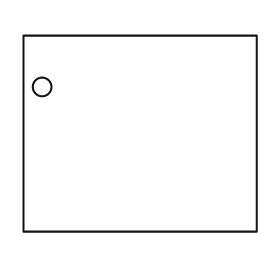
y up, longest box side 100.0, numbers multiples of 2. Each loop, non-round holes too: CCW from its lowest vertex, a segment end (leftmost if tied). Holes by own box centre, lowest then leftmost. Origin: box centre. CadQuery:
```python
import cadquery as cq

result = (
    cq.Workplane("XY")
    .moveTo(-50.0, -42.0)
    .lineTo(50.0, -42.0)
    .lineTo(50.0, 42.0)
    .lineTo(-50.0, 42.0)
    .close()
    .moveTo(-42.0, 20.0)
    .circle(4.0)
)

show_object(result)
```